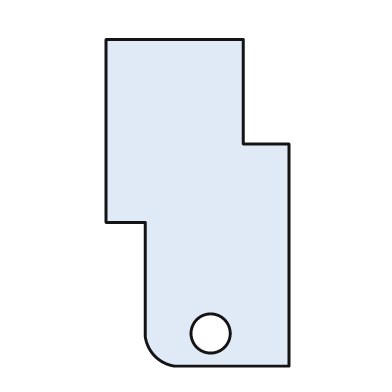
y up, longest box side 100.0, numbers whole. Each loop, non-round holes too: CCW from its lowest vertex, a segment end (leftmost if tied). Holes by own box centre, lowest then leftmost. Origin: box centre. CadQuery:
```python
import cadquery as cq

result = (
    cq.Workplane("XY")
    .moveTo(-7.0, -50.0)
    .lineTo(28.0, -50.0)
    .lineTo(28.0, 18.0)
    .lineTo(14.0, 18.0)
    .lineTo(14.0, 50.0)
    .lineTo(-28.0, 50.0)
    .lineTo(-28.0, -6.0)
    .lineTo(-16.0, -6.0)
    .lineTo(-16.0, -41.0)
    .threePointArc((-13.0, -47.0), (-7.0, -50.0))
    .close()
    .moveTo(4.0, -40.0)
    .circle(6.0)
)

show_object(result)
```